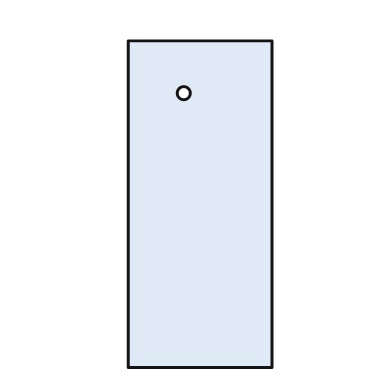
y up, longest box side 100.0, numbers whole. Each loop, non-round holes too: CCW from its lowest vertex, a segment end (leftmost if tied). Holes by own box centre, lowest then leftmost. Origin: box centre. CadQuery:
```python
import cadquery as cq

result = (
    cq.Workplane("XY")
    .moveTo(-22.0, -50.0)
    .lineTo(22.0, -50.0)
    .lineTo(22.0, 50.0)
    .lineTo(-22.0, 50.0)
    .close()
    .moveTo(-5.0, 34.0)
    .circle(2.0)
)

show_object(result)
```